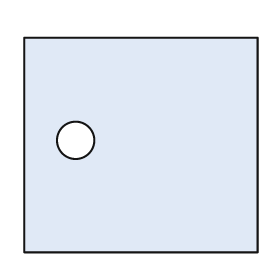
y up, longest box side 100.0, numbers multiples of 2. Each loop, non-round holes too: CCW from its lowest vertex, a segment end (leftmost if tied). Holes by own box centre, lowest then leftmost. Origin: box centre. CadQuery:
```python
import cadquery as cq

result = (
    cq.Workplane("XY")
    .moveTo(-50.0, -46.0)
    .lineTo(50.0, -46.0)
    .lineTo(50.0, 46.0)
    .lineTo(-50.0, 46.0)
    .close()
    .moveTo(-28.0, 2.0)
    .circle(8.0)
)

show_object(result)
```